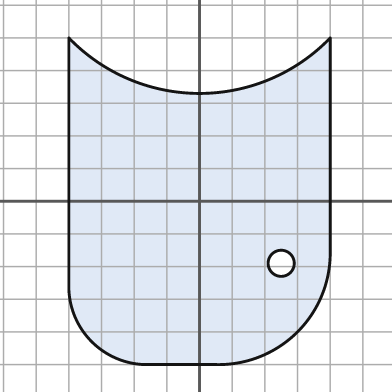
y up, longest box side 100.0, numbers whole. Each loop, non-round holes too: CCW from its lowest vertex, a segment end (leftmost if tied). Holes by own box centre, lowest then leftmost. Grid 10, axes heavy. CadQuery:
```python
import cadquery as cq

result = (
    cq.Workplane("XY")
    .moveTo(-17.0, -50.0)
    .lineTo(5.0, -50.0)
    .threePointArc((30.0, -40.0), (40.0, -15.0))
    .lineTo(40.0, 50.0)
    .threePointArc((0.0, 33.0), (-40.0, 50.0))
    .lineTo(-40.0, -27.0)
    .threePointArc((-33.0, -43.0), (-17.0, -50.0))
    .close()
    .moveTo(25.0, -19.0)
    .circle(4.0)
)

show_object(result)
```